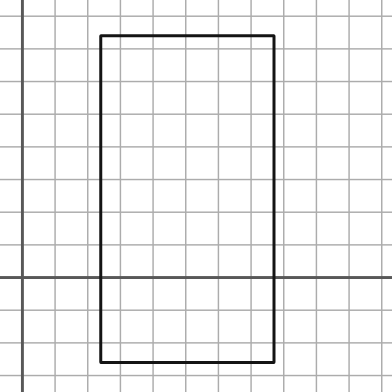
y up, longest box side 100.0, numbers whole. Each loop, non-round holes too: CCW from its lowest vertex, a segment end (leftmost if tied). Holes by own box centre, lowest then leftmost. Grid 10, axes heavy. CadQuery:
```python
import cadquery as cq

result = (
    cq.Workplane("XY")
    .moveTo(24.0, -26.0)
    .lineTo(77.0, -26.0)
    .lineTo(77.0, 74.0)
    .lineTo(24.0, 74.0)
    .close()
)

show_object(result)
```